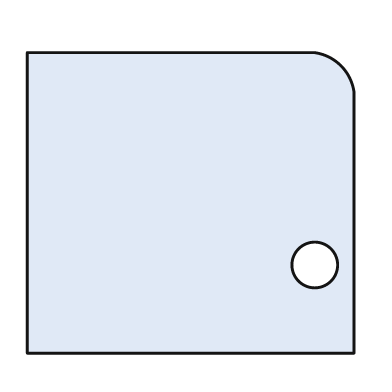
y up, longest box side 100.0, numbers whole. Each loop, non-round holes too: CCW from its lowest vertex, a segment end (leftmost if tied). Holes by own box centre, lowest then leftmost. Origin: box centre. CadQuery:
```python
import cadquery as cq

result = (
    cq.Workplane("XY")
    .moveTo(-50.0, -46.0)
    .lineTo(50.0, -46.0)
    .lineTo(50.0, 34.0)
    .threePointArc((46.0, 42.0), (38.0, 46.0))
    .lineTo(-50.0, 46.0)
    .close()
    .moveTo(38.0, -19.0)
    .circle(7.0)
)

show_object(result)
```